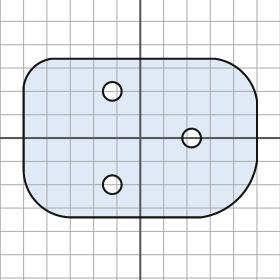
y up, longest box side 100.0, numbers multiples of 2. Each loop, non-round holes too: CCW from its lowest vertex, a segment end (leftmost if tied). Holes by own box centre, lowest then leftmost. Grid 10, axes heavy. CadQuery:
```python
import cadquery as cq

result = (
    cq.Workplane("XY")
    .moveTo(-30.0, -34.0)
    .lineTo(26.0, -34.0)
    .threePointArc((42.0, -26.0), (50.0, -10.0))
    .lineTo(50.0, 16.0)
    .threePointArc((44.0, 28.0), (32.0, 34.0))
    .lineTo(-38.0, 34.0)
    .threePointArc((-46.0, 30.0), (-50.0, 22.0))
    .lineTo(-50.0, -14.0)
    .threePointArc((-44.0, -28.0), (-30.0, -34.0))
    .close()
    .moveTo(-12.0, -20.0)
    .circle(4.0)
    .moveTo(22.0, 0.0)
    .circle(4.0)
    .moveTo(-12.0, 20.0)
    .circle(4.0)
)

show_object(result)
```